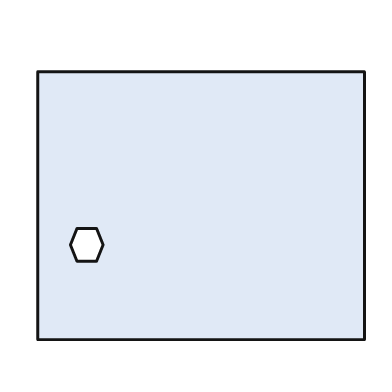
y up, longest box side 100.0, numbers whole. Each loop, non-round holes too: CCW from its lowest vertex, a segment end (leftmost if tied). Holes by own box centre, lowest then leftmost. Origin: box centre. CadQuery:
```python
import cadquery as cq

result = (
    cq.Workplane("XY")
    .moveTo(-50.0, -41.0)
    .lineTo(50.0, -41.0)
    .lineTo(50.0, 41.0)
    .lineTo(-50.0, 41.0)
    .close()
    .moveTo(-38.0, -17.0)
    .lineTo(-32.0, -17.0)
    .lineTo(-30.0, -12.0)
    .lineTo(-32.0, -7.0)
    .lineTo(-38.0, -7.0)
    .lineTo(-40.0, -12.0)
    .close()
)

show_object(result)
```